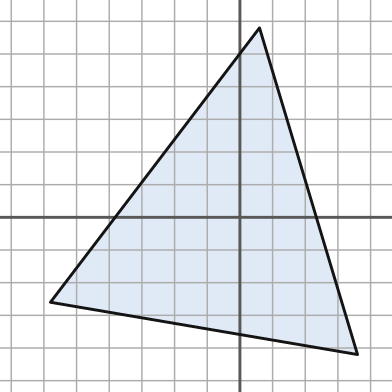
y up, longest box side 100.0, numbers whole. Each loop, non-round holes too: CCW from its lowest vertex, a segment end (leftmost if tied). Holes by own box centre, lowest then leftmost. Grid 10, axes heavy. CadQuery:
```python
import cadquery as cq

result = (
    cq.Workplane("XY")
    .moveTo(36.0, -42.0)
    .lineTo(6.0, 58.0)
    .lineTo(-58.0, -26.0)
    .close()
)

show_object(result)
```